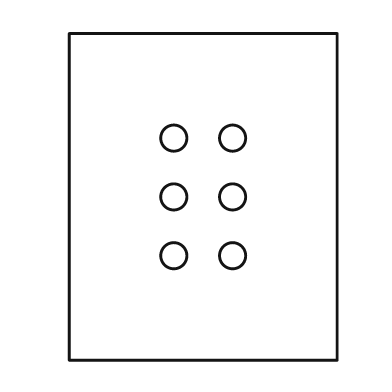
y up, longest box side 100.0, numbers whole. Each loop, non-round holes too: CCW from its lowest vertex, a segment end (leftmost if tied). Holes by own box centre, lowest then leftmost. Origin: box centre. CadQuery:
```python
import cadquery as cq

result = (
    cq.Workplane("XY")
    .moveTo(-41.0, -50.0)
    .lineTo(41.0, -50.0)
    .lineTo(41.0, 50.0)
    .lineTo(-41.0, 50.0)
    .close()
    .moveTo(-9.0, -18.0)
    .circle(4.0)
    .moveTo(9.0, -18.0)
    .circle(4.0)
    .moveTo(-9.0, 0.0)
    .circle(4.0)
    .moveTo(9.0, 0.0)
    .circle(4.0)
    .moveTo(-9.0, 18.0)
    .circle(4.0)
    .moveTo(9.0, 18.0)
    .circle(4.0)
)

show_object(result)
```